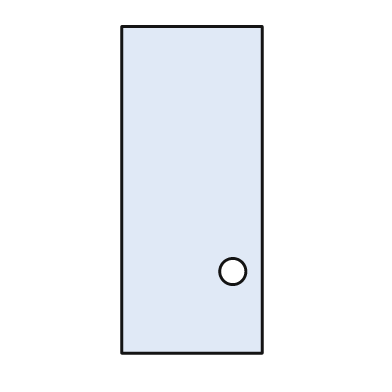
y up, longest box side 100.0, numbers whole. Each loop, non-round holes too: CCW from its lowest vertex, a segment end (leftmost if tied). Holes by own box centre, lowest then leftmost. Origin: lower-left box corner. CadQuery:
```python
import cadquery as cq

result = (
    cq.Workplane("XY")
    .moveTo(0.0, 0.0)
    .lineTo(43.0, 0.0)
    .lineTo(43.0, 100.0)
    .lineTo(0.0, 100.0)
    .close()
    .moveTo(34.0, 25.0)
    .circle(4.0)
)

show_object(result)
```